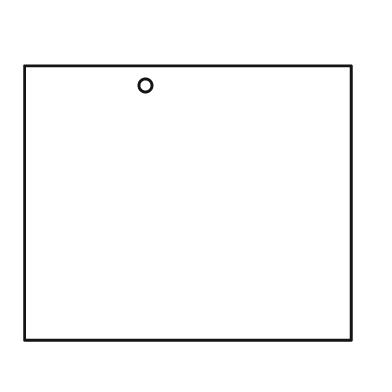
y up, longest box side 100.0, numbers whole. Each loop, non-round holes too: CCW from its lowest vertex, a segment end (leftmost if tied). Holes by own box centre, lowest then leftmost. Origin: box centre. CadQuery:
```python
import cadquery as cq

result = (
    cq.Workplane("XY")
    .moveTo(-50.0, -42.0)
    .lineTo(50.0, -42.0)
    .lineTo(50.0, 42.0)
    .lineTo(-50.0, 42.0)
    .close()
    .moveTo(-13.0, 36.0)
    .circle(2.0)
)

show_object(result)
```